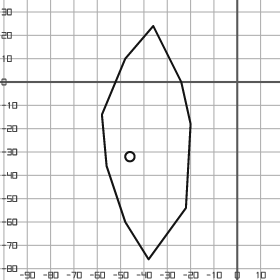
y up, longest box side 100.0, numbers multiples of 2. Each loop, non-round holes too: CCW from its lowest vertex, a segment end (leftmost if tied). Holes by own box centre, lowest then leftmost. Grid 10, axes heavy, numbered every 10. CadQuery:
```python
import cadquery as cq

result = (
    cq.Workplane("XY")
    .moveTo(-38.0, -76.0)
    .lineTo(-22.0, -54.0)
    .lineTo(-20.0, -18.0)
    .lineTo(-24.0, 0.0)
    .lineTo(-36.0, 24.0)
    .lineTo(-48.0, 10.0)
    .lineTo(-58.0, -14.0)
    .lineTo(-56.0, -36.0)
    .lineTo(-48.0, -60.0)
    .close()
    .moveTo(-46.0, -32.0)
    .circle(2.0)
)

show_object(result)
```